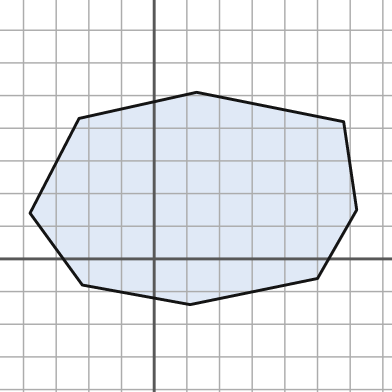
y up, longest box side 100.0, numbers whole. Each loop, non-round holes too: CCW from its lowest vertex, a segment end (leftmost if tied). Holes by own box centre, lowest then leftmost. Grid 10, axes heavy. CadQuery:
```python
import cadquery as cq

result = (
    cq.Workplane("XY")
    .moveTo(11.0, -14.0)
    .lineTo(50.0, -6.0)
    .lineTo(62.0, 15.0)
    .lineTo(58.0, 42.0)
    .lineTo(13.0, 51.0)
    .lineTo(-23.0, 43.0)
    .lineTo(-38.0, 14.0)
    .lineTo(-22.0, -8.0)
    .close()
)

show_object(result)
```